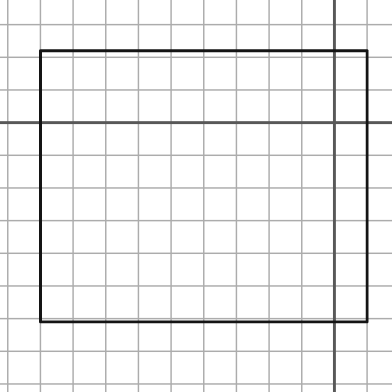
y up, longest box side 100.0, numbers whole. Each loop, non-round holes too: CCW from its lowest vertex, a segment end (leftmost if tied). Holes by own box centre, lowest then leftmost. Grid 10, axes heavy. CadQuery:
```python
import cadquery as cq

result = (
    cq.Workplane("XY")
    .moveTo(-90.0, -61.0)
    .lineTo(10.0, -61.0)
    .lineTo(10.0, 22.0)
    .lineTo(-90.0, 22.0)
    .close()
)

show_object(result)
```